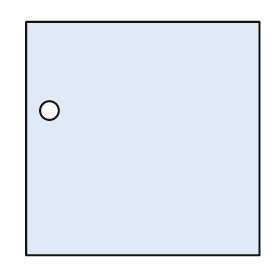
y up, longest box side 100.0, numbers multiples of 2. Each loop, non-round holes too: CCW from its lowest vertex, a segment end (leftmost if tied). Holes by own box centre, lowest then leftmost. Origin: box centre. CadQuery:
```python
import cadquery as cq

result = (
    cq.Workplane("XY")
    .moveTo(-50.0, -50.0)
    .lineTo(50.0, -50.0)
    .lineTo(50.0, 50.0)
    .lineTo(-50.0, 50.0)
    .close()
    .moveTo(-40.0, 12.0)
    .circle(4.0)
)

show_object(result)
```